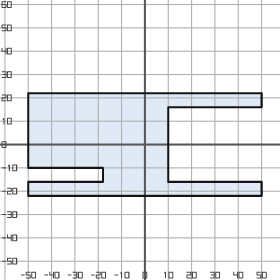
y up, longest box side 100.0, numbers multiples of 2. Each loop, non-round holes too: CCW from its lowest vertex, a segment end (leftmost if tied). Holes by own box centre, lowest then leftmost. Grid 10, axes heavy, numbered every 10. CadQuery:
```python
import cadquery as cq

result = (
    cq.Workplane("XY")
    .moveTo(-50.0, -22.0)
    .lineTo(50.0, -22.0)
    .lineTo(50.0, -16.0)
    .lineTo(10.0, -16.0)
    .lineTo(10.0, 16.0)
    .lineTo(50.0, 16.0)
    .lineTo(50.0, 22.0)
    .lineTo(-50.0, 22.0)
    .lineTo(-50.0, -10.0)
    .lineTo(-18.0, -10.0)
    .lineTo(-18.0, -16.0)
    .lineTo(-50.0, -16.0)
    .close()
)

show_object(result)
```